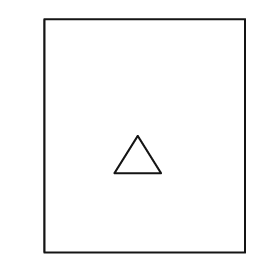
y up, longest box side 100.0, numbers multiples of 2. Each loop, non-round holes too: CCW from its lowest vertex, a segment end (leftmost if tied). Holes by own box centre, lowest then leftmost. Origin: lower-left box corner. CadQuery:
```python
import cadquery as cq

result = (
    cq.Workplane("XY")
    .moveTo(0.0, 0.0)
    .lineTo(86.0, 0.0)
    .lineTo(86.0, 100.0)
    .lineTo(0.0, 100.0)
    .close()
    .moveTo(30.0, 34.0)
    .lineTo(50.0, 34.0)
    .lineTo(40.0, 50.0)
    .close()
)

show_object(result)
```